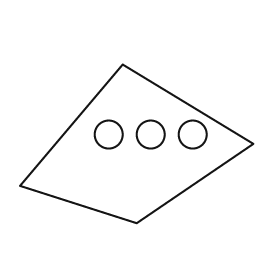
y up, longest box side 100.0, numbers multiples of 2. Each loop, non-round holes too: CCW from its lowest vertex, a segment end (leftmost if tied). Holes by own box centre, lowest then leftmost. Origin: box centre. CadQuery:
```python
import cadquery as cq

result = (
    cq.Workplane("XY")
    .moveTo(0.0, -34.0)
    .lineTo(50.0, 0.0)
    .lineTo(-6.0, 34.0)
    .lineTo(-50.0, -18.0)
    .close()
    .moveTo(-12.0, 4.0)
    .circle(6.0)
    .moveTo(6.0, 4.0)
    .circle(6.0)
    .moveTo(24.0, 4.0)
    .circle(6.0)
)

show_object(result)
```